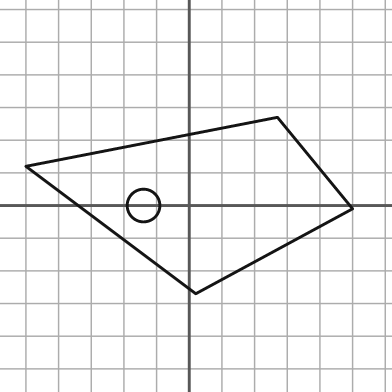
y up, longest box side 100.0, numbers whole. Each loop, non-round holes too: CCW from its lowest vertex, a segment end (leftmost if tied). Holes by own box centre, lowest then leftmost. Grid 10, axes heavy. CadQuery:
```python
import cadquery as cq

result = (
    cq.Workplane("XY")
    .moveTo(2.0, -27.0)
    .lineTo(50.0, -1.0)
    .lineTo(27.0, 27.0)
    .lineTo(-50.0, 12.0)
    .close()
    .moveTo(-14.0, 0.0)
    .circle(5.0)
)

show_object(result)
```